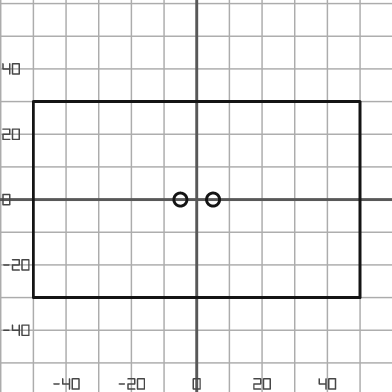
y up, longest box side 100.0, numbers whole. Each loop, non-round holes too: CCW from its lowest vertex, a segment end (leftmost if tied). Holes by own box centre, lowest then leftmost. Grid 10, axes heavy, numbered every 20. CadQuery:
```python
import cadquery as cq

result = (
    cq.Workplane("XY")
    .moveTo(-50.0, -30.0)
    .lineTo(50.0, -30.0)
    .lineTo(50.0, 30.0)
    .lineTo(-50.0, 30.0)
    .close()
    .moveTo(-5.0, 0.0)
    .circle(2.0)
    .moveTo(5.0, 0.0)
    .circle(2.0)
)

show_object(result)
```